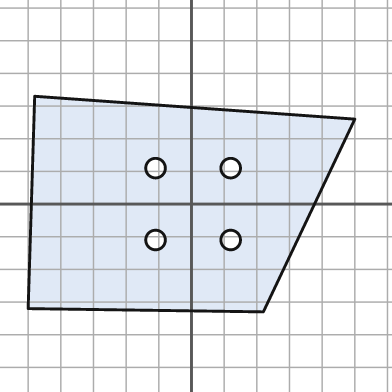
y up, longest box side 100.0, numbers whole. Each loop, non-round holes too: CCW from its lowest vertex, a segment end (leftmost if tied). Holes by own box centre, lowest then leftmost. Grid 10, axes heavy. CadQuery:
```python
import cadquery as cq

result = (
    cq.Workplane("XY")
    .moveTo(22.0, -33.0)
    .lineTo(50.0, 26.0)
    .lineTo(-48.0, 33.0)
    .lineTo(-50.0, -32.0)
    .close()
    .moveTo(-11.0, -11.0)
    .circle(3.0)
    .moveTo(12.0, -11.0)
    .circle(3.0)
    .moveTo(-11.0, 11.0)
    .circle(3.0)
    .moveTo(12.0, 11.0)
    .circle(3.0)
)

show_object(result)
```